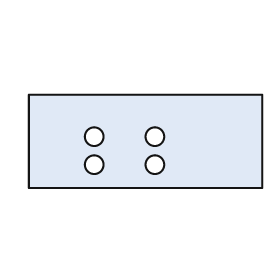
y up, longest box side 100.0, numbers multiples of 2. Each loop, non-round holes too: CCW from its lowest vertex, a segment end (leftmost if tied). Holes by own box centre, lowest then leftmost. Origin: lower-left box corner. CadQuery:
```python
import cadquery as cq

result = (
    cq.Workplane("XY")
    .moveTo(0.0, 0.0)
    .lineTo(100.0, 0.0)
    .lineTo(100.0, 40.0)
    .lineTo(0.0, 40.0)
    .close()
    .moveTo(28.0, 10.0)
    .circle(4.0)
    .moveTo(54.0, 10.0)
    .circle(4.0)
    .moveTo(28.0, 22.0)
    .circle(4.0)
    .moveTo(54.0, 22.0)
    .circle(4.0)
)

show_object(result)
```